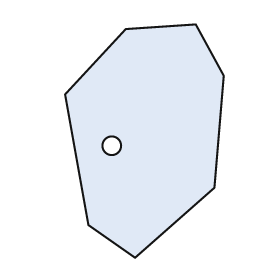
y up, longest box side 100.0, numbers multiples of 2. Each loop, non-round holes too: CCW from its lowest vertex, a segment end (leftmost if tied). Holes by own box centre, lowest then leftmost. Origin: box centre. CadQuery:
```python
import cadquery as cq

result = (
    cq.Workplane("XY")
    .moveTo(-4.0, -50.0)
    .lineTo(30.0, -20.0)
    .lineTo(34.0, 28.0)
    .lineTo(22.0, 50.0)
    .lineTo(-8.0, 48.0)
    .lineTo(-34.0, 20.0)
    .lineTo(-24.0, -36.0)
    .close()
    .moveTo(-14.0, -2.0)
    .circle(4.0)
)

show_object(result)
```